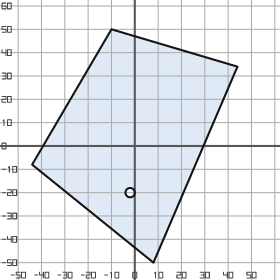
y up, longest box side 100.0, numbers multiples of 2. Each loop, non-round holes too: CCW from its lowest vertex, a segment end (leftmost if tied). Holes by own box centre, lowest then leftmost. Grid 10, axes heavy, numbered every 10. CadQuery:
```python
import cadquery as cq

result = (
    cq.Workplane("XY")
    .moveTo(8.0, -50.0)
    .lineTo(44.0, 34.0)
    .lineTo(-10.0, 50.0)
    .lineTo(-44.0, -8.0)
    .close()
    .moveTo(-2.0, -20.0)
    .circle(2.0)
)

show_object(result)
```